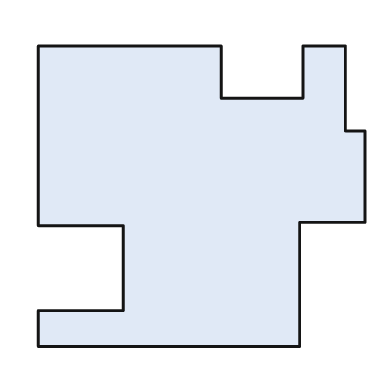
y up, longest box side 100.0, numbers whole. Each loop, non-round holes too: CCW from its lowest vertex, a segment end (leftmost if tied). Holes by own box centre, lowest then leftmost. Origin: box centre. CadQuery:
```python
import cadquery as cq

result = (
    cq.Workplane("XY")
    .moveTo(-50.0, -46.0)
    .lineTo(30.0, -46.0)
    .lineTo(30.0, -8.0)
    .lineTo(50.0, -8.0)
    .lineTo(50.0, 20.0)
    .lineTo(44.0, 20.0)
    .lineTo(44.0, 46.0)
    .lineTo(31.0, 46.0)
    .lineTo(31.0, 30.0)
    .lineTo(6.0, 30.0)
    .lineTo(6.0, 46.0)
    .lineTo(-50.0, 46.0)
    .lineTo(-50.0, -9.0)
    .lineTo(-24.0, -9.0)
    .lineTo(-24.0, -35.0)
    .lineTo(-50.0, -35.0)
    .close()
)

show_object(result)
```